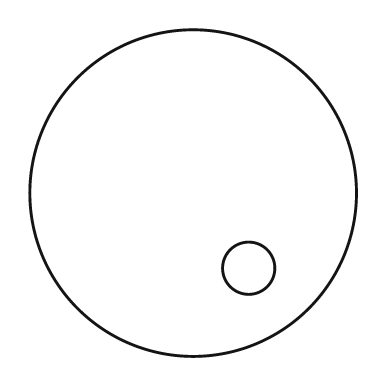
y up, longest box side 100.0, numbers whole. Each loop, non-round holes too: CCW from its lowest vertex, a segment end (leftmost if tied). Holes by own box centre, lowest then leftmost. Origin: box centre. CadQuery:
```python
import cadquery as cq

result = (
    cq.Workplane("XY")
    .moveTo(0.0, 0.0)
    .circle(50.0)
    .moveTo(17.0, -23.0)
    .circle(8.0)
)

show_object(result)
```